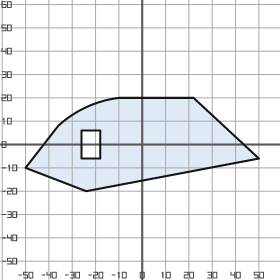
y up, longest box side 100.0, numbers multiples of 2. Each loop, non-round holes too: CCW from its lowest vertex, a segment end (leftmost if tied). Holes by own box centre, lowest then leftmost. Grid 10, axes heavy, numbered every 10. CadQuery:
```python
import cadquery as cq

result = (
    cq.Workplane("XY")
    .moveTo(-24.0, -20.0)
    .lineTo(50.0, -6.0)
    .lineTo(22.0, 20.0)
    .lineTo(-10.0, 20.0)
    .threePointArc((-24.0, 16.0), (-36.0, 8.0))
    .lineTo(-50.0, -10.0)
    .close()
    .moveTo(-26.0, -6.0)
    .lineTo(-18.0, -6.0)
    .lineTo(-18.0, 6.0)
    .lineTo(-26.0, 6.0)
    .close()
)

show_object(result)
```